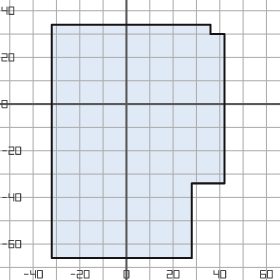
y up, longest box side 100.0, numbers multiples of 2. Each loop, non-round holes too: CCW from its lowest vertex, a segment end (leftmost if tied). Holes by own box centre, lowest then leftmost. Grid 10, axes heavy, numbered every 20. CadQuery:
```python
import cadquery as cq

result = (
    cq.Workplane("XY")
    .moveTo(-32.0, -66.0)
    .lineTo(28.0, -66.0)
    .lineTo(28.0, -34.0)
    .lineTo(42.0, -34.0)
    .lineTo(42.0, 30.0)
    .lineTo(36.0, 30.0)
    .lineTo(36.0, 34.0)
    .lineTo(-32.0, 34.0)
    .close()
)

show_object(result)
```